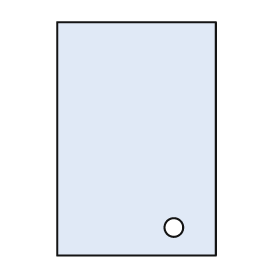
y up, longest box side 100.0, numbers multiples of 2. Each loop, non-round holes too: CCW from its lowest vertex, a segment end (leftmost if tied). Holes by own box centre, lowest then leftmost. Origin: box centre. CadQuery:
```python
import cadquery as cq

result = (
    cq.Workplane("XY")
    .moveTo(-34.0, -50.0)
    .lineTo(34.0, -50.0)
    .lineTo(34.0, 50.0)
    .lineTo(-34.0, 50.0)
    .close()
    .moveTo(16.0, -38.0)
    .circle(4.0)
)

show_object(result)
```